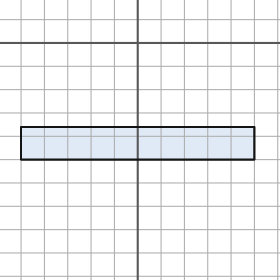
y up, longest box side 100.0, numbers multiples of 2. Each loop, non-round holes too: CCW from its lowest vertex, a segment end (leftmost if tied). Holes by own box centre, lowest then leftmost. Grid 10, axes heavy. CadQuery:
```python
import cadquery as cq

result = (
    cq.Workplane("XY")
    .moveTo(-50.0, -50.0)
    .lineTo(50.0, -50.0)
    .lineTo(50.0, -36.0)
    .lineTo(-50.0, -36.0)
    .close()
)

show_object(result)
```